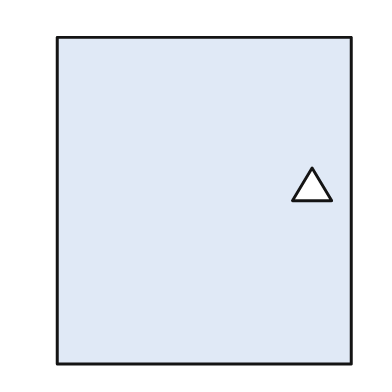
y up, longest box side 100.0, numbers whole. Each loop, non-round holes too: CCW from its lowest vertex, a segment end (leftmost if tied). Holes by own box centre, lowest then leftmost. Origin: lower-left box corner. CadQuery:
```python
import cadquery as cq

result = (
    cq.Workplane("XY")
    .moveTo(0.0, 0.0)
    .lineTo(90.0, 0.0)
    .lineTo(90.0, 100.0)
    .lineTo(0.0, 100.0)
    .close()
    .moveTo(72.0, 50.0)
    .lineTo(84.0, 50.0)
    .lineTo(78.0, 60.0)
    .close()
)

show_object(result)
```